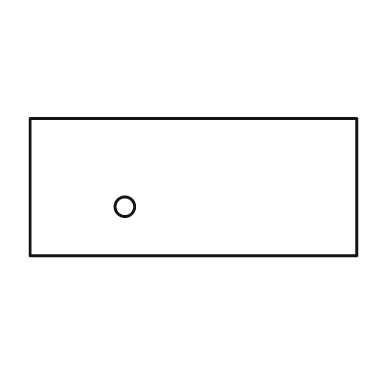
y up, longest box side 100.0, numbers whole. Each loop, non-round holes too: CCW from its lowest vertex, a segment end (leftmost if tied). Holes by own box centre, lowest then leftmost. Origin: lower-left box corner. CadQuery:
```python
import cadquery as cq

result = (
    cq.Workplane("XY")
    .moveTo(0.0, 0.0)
    .lineTo(100.0, 0.0)
    .lineTo(100.0, 42.0)
    .lineTo(0.0, 42.0)
    .close()
    .moveTo(29.0, 15.0)
    .circle(3.0)
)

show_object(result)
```